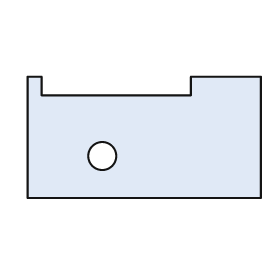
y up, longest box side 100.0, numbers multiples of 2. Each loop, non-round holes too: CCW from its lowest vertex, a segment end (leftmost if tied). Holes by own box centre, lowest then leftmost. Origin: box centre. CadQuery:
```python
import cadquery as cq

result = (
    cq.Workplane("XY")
    .moveTo(-50.0, -26.0)
    .lineTo(50.0, -26.0)
    .lineTo(50.0, 26.0)
    .lineTo(20.0, 26.0)
    .lineTo(20.0, 18.0)
    .lineTo(-44.0, 18.0)
    .lineTo(-44.0, 26.0)
    .lineTo(-50.0, 26.0)
    .close()
    .moveTo(-18.0, -8.0)
    .circle(6.0)
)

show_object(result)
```